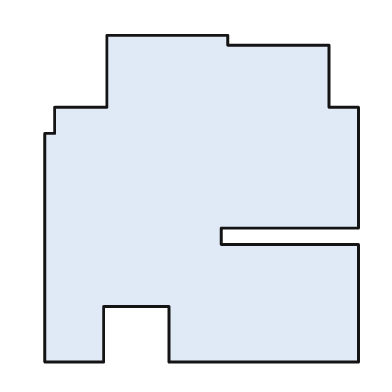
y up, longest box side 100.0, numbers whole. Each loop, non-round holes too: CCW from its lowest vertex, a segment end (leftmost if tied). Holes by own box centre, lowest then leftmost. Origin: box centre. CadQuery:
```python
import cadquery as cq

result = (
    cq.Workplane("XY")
    .moveTo(-48.0, -50.0)
    .lineTo(-30.0, -50.0)
    .lineTo(-30.0, -33.0)
    .lineTo(-10.0, -33.0)
    .lineTo(-10.0, -50.0)
    .lineTo(48.0, -50.0)
    .lineTo(48.0, -14.0)
    .lineTo(6.0, -14.0)
    .lineTo(6.0, -9.0)
    .lineTo(48.0, -9.0)
    .lineTo(48.0, 28.0)
    .lineTo(39.0, 28.0)
    .lineTo(39.0, 47.0)
    .lineTo(8.0, 47.0)
    .lineTo(8.0, 50.0)
    .lineTo(-29.0, 50.0)
    .lineTo(-29.0, 28.0)
    .lineTo(-45.0, 28.0)
    .lineTo(-45.0, 20.0)
    .lineTo(-48.0, 20.0)
    .close()
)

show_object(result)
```